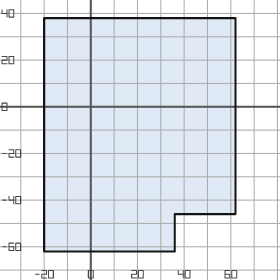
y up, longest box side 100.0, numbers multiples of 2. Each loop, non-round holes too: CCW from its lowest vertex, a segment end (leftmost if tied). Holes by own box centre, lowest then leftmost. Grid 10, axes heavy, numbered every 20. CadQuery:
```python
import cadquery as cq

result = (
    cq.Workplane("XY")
    .moveTo(-20.0, -62.0)
    .lineTo(36.0, -62.0)
    .lineTo(36.0, -46.0)
    .lineTo(62.0, -46.0)
    .lineTo(62.0, 38.0)
    .lineTo(-20.0, 38.0)
    .close()
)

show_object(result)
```